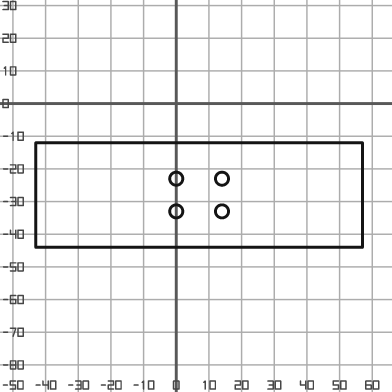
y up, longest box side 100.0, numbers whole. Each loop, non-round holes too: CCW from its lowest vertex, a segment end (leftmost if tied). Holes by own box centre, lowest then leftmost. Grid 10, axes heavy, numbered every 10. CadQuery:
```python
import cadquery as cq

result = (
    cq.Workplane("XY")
    .moveTo(-43.0, -44.0)
    .lineTo(57.0, -44.0)
    .lineTo(57.0, -12.0)
    .lineTo(-43.0, -12.0)
    .close()
    .moveTo(0.0, -33.0)
    .circle(2.0)
    .moveTo(14.0, -33.0)
    .circle(2.0)
    .moveTo(0.0, -23.0)
    .circle(2.0)
    .moveTo(14.0, -23.0)
    .circle(2.0)
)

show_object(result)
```